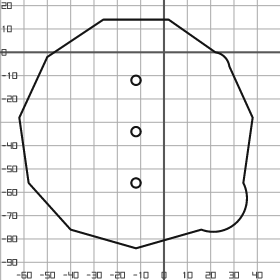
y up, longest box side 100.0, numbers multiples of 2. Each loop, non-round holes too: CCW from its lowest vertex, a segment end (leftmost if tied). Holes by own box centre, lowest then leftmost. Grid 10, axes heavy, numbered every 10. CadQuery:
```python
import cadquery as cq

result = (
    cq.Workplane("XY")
    .moveTo(-12.0, -84.0)
    .lineTo(16.0, -76.0)
    .threePointArc((32.0, -72.0), (34.0, -56.0))
    .lineTo(38.0, -28.0)
    .lineTo(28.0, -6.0)
    .threePointArc((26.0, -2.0), (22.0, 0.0))
    .lineTo(2.0, 14.0)
    .lineTo(-26.0, 14.0)
    .lineTo(-50.0, -2.0)
    .lineTo(-62.0, -28.0)
    .lineTo(-58.0, -56.0)
    .lineTo(-40.0, -76.0)
    .close()
    .moveTo(-12.0, -56.0)
    .circle(2.0)
    .moveTo(-12.0, -34.0)
    .circle(2.0)
    .moveTo(-12.0, -12.0)
    .circle(2.0)
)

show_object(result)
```